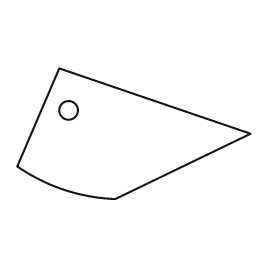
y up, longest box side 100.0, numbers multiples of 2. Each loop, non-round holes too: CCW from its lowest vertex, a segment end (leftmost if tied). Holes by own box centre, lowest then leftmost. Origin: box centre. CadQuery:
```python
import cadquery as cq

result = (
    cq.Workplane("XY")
    .moveTo(-8.0, -28.0)
    .lineTo(50.0, 0.0)
    .lineTo(-32.0, 28.0)
    .lineTo(-50.0, -14.0)
    .threePointArc((-30.0, -24.0), (-8.0, -28.0))
    .close()
    .moveTo(-28.0, 10.0)
    .circle(4.0)
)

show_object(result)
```